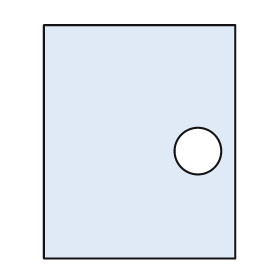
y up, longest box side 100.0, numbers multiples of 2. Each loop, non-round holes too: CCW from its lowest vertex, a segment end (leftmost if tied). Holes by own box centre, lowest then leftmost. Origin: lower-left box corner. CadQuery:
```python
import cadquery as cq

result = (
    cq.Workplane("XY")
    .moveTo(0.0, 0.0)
    .lineTo(82.0, 0.0)
    .lineTo(82.0, 100.0)
    .lineTo(0.0, 100.0)
    .close()
    .moveTo(66.0, 46.0)
    .circle(10.0)
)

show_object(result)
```